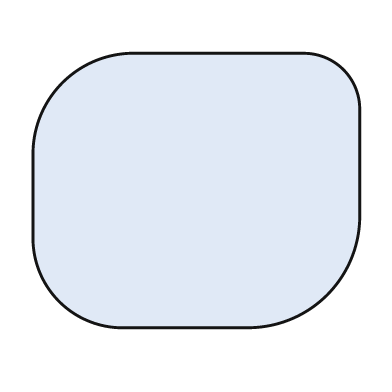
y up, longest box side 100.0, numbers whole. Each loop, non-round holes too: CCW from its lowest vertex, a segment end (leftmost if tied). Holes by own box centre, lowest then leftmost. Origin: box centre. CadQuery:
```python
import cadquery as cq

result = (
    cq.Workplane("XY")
    .moveTo(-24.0, -42.0)
    .lineTo(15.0, -42.0)
    .threePointArc((40.0, -32.0), (50.0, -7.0))
    .lineTo(50.0, 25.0)
    .threePointArc((45.0, 37.0), (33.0, 42.0))
    .lineTo(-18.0, 42.0)
    .threePointArc((-41.0, 33.0), (-50.0, 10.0))
    .lineTo(-50.0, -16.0)
    .threePointArc((-42.0, -34.0), (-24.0, -42.0))
    .close()
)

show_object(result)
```